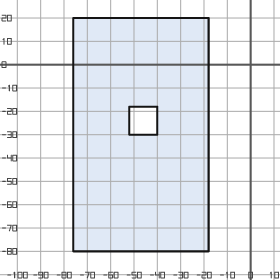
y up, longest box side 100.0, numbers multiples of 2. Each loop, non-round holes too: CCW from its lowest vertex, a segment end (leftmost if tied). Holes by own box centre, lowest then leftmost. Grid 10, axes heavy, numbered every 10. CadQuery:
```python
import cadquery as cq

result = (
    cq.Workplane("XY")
    .moveTo(-76.0, -80.0)
    .lineTo(-18.0, -80.0)
    .lineTo(-18.0, 20.0)
    .lineTo(-76.0, 20.0)
    .close()
    .moveTo(-52.0, -30.0)
    .lineTo(-40.0, -30.0)
    .lineTo(-40.0, -18.0)
    .lineTo(-52.0, -18.0)
    .close()
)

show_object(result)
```